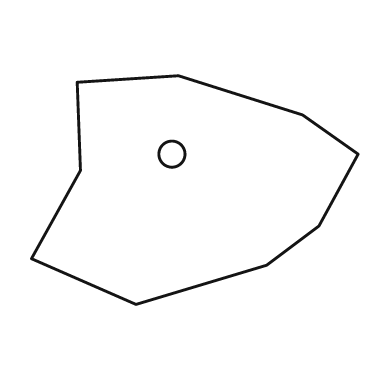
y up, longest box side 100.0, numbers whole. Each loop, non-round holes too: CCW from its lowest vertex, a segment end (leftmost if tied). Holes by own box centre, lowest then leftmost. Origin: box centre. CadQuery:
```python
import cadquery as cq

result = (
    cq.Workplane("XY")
    .moveTo(-18.0, -35.0)
    .lineTo(22.0, -23.0)
    .lineTo(38.0, -11.0)
    .lineTo(50.0, 11.0)
    .lineTo(33.0, 23.0)
    .lineTo(-5.0, 35.0)
    .lineTo(-36.0, 33.0)
    .lineTo(-35.0, 6.0)
    .lineTo(-50.0, -21.0)
    .close()
    .moveTo(-7.0, 11.0)
    .circle(4.0)
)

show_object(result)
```